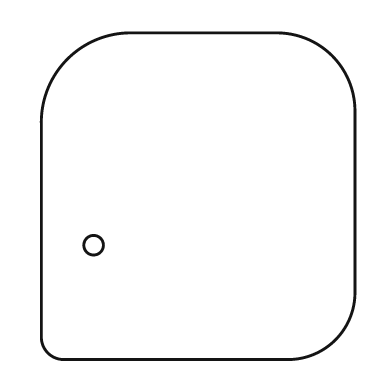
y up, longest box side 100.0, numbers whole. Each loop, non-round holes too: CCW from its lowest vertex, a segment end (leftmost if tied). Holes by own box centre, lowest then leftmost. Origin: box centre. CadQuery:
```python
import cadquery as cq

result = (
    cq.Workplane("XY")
    .moveTo(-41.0, -50.0)
    .lineTo(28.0, -50.0)
    .threePointArc((42.0, -44.0), (48.0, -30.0))
    .lineTo(48.0, 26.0)
    .threePointArc((41.0, 43.0), (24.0, 50.0))
    .lineTo(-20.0, 50.0)
    .threePointArc((-40.0, 42.0), (-48.0, 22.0))
    .lineTo(-48.0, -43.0)
    .threePointArc((-46.0, -48.0), (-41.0, -50.0))
    .close()
    .moveTo(-32.0, -15.0)
    .circle(3.0)
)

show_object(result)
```